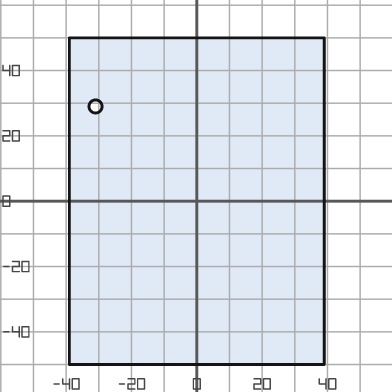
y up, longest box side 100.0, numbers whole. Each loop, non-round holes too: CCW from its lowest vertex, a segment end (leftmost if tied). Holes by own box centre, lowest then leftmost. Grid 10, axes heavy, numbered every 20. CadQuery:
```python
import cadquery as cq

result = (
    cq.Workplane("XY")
    .moveTo(-39.0, -50.0)
    .lineTo(39.0, -50.0)
    .lineTo(39.0, 50.0)
    .lineTo(-39.0, 50.0)
    .close()
    .moveTo(-31.0, 29.0)
    .circle(2.0)
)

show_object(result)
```